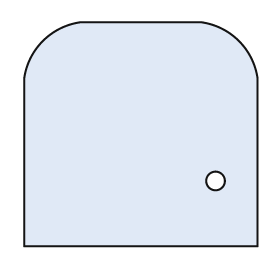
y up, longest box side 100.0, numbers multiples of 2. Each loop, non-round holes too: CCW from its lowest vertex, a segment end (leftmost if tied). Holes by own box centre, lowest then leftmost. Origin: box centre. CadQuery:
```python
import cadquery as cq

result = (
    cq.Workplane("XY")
    .moveTo(-50.0, -48.0)
    .lineTo(50.0, -48.0)
    .lineTo(50.0, 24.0)
    .threePointArc((42.0, 40.0), (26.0, 48.0))
    .lineTo(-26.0, 48.0)
    .threePointArc((-42.0, 40.0), (-50.0, 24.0))
    .close()
    .moveTo(32.0, -20.0)
    .circle(4.0)
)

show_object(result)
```